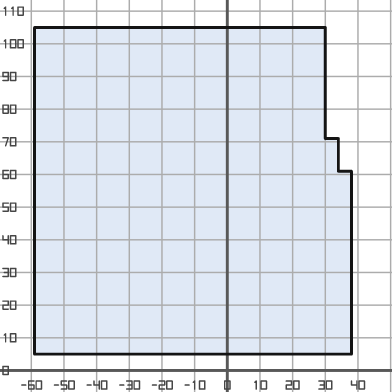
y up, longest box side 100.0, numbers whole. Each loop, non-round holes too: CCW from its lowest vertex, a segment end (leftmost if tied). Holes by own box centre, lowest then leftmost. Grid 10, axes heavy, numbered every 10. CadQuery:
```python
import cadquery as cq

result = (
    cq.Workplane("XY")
    .moveTo(-59.0, 5.0)
    .lineTo(38.0, 5.0)
    .lineTo(38.0, 61.0)
    .lineTo(34.0, 61.0)
    .lineTo(34.0, 71.0)
    .lineTo(30.0, 71.0)
    .lineTo(30.0, 105.0)
    .lineTo(-59.0, 105.0)
    .close()
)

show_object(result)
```